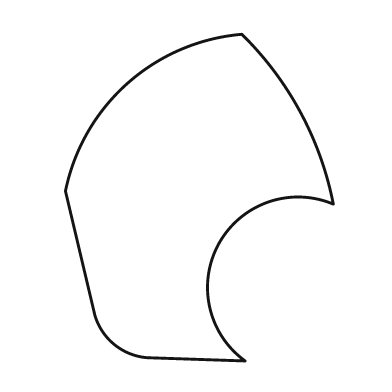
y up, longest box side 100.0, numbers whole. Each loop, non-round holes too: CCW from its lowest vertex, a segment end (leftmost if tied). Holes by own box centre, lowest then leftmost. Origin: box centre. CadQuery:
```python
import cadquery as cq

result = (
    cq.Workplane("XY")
    .moveTo(14.0, -50.0)
    .threePointArc((6.0, -14.0), (41.0, -2.0))
    .threePointArc((31.0, 26.0), (13.0, 50.0))
    .threePointArc((-22.0, 35.0), (-41.0, 2.0))
    .lineTo(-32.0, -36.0)
    .threePointArc((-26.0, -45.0), (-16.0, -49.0))
    .close()
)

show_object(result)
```